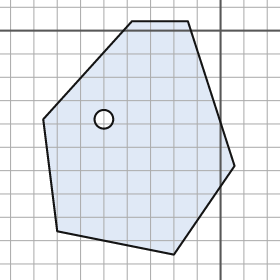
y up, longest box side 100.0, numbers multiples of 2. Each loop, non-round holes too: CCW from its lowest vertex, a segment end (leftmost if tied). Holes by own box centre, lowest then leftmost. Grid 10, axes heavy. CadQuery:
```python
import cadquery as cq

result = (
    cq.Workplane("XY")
    .moveTo(-20.0, -96.0)
    .lineTo(6.0, -58.0)
    .lineTo(-14.0, 4.0)
    .lineTo(-38.0, 4.0)
    .lineTo(-76.0, -38.0)
    .lineTo(-70.0, -86.0)
    .close()
    .moveTo(-50.0, -38.0)
    .circle(4.0)
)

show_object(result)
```